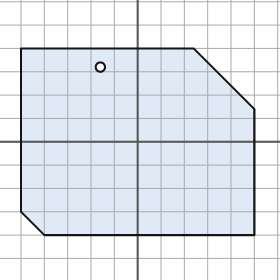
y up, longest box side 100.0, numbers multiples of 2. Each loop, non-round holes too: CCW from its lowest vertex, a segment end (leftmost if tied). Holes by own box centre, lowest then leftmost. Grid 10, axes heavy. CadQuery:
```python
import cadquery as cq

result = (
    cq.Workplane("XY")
    .moveTo(-40.0, -40.0)
    .lineTo(50.0, -40.0)
    .lineTo(50.0, 14.0)
    .lineTo(24.0, 40.0)
    .lineTo(-50.0, 40.0)
    .lineTo(-50.0, -30.0)
    .close()
    .moveTo(-16.0, 32.0)
    .circle(2.0)
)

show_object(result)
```